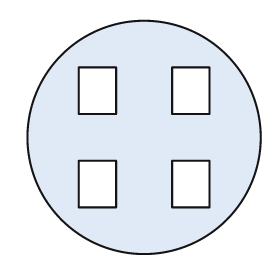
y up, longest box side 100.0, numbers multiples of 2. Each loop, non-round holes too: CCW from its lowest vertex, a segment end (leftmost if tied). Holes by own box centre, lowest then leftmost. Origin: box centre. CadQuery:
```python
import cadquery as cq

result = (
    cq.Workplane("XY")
    .moveTo(0.0, 0.0)
    .circle(50.0)
    .moveTo(-28.0, -30.0)
    .lineTo(-12.0, -30.0)
    .lineTo(-12.0, -10.0)
    .lineTo(-28.0, -10.0)
    .close()
    .moveTo(12.0, -30.0)
    .lineTo(28.0, -30.0)
    .lineTo(28.0, -10.0)
    .lineTo(12.0, -10.0)
    .close()
    .moveTo(-28.0, 10.0)
    .lineTo(-12.0, 10.0)
    .lineTo(-12.0, 30.0)
    .lineTo(-28.0, 30.0)
    .close()
    .moveTo(12.0, 10.0)
    .lineTo(28.0, 10.0)
    .lineTo(28.0, 30.0)
    .lineTo(12.0, 30.0)
    .close()
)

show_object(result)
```